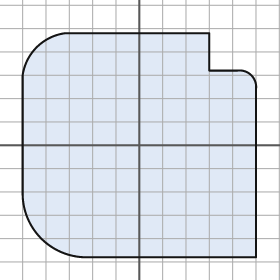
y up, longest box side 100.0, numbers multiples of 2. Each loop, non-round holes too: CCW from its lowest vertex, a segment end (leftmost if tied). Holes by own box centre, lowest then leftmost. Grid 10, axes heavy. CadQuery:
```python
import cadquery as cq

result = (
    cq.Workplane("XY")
    .moveTo(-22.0, -48.0)
    .lineTo(50.0, -48.0)
    .lineTo(50.0, 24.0)
    .threePointArc((48.0, 30.0), (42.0, 32.0))
    .lineTo(30.0, 32.0)
    .lineTo(30.0, 48.0)
    .lineTo(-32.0, 48.0)
    .threePointArc((-44.0, 42.0), (-50.0, 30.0))
    .lineTo(-50.0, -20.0)
    .threePointArc((-42.0, -40.0), (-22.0, -48.0))
    .close()
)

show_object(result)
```